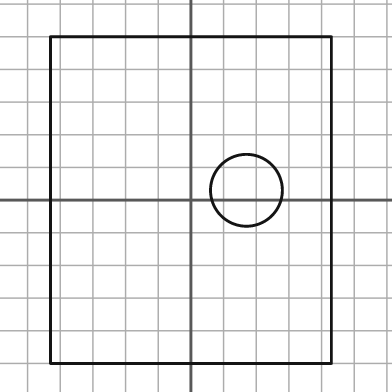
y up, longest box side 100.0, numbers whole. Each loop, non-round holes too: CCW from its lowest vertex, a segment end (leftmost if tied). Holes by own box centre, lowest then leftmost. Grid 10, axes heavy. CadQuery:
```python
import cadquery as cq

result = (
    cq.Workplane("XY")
    .moveTo(-43.0, -50.0)
    .lineTo(43.0, -50.0)
    .lineTo(43.0, 50.0)
    .lineTo(-43.0, 50.0)
    .close()
    .moveTo(17.0, 3.0)
    .circle(11.0)
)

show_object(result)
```